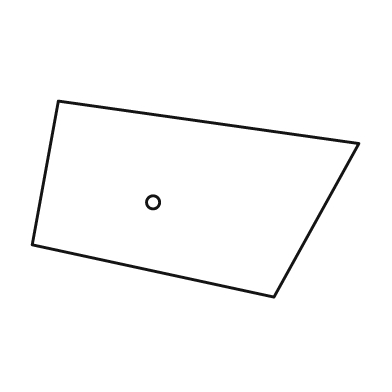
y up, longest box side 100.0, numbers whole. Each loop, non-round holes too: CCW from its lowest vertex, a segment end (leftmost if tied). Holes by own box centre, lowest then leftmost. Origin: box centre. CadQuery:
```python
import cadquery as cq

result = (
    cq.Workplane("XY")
    .moveTo(24.0, -30.0)
    .lineTo(50.0, 17.0)
    .lineTo(-42.0, 30.0)
    .lineTo(-50.0, -14.0)
    .close()
    .moveTo(-13.0, -1.0)
    .circle(2.0)
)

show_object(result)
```